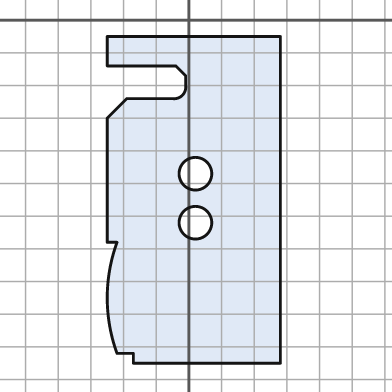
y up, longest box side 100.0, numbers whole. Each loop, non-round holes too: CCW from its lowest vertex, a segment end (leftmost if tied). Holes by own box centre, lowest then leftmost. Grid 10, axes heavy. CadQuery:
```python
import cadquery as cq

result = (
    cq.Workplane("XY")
    .moveTo(-17.0, -105.0)
    .lineTo(28.0, -105.0)
    .lineTo(28.0, -5.0)
    .lineTo(-25.0, -5.0)
    .lineTo(-25.0, -14.0)
    .lineTo(-4.0, -14.0)
    .lineTo(-1.0, -17.0)
    .lineTo(-1.0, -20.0)
    .threePointArc((-2.0, -23.0), (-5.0, -24.0))
    .lineTo(-19.0, -24.0)
    .lineTo(-25.0, -30.0)
    .lineTo(-25.0, -68.0)
    .lineTo(-22.0, -68.0)
    .threePointArc((-25.0, -85.0), (-22.0, -102.0))
    .lineTo(-17.0, -102.0)
    .close()
    .moveTo(2.0, -62.0)
    .circle(5.0)
    .moveTo(2.0, -47.0)
    .circle(5.0)
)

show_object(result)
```